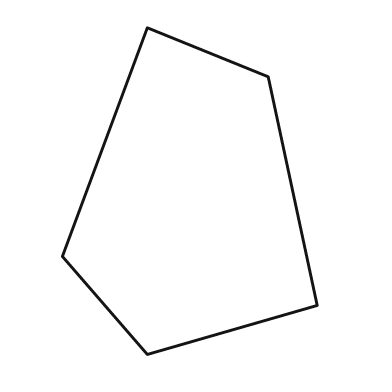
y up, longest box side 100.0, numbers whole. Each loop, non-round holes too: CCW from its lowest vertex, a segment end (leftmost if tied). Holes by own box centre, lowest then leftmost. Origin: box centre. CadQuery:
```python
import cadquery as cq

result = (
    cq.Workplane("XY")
    .moveTo(-13.0, -50.0)
    .lineTo(39.0, -35.0)
    .lineTo(24.0, 35.0)
    .lineTo(-13.0, 50.0)
    .lineTo(-39.0, -20.0)
    .close()
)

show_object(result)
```